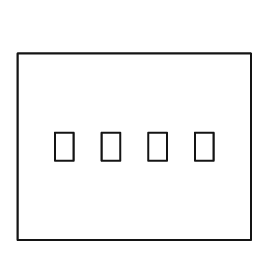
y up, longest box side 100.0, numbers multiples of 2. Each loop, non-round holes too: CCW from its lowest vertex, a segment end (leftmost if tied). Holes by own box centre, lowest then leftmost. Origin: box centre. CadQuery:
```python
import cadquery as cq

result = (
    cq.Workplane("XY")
    .moveTo(-50.0, -40.0)
    .lineTo(50.0, -40.0)
    .lineTo(50.0, 40.0)
    .lineTo(-50.0, 40.0)
    .close()
    .moveTo(-34.0, -6.0)
    .lineTo(-26.0, -6.0)
    .lineTo(-26.0, 6.0)
    .lineTo(-34.0, 6.0)
    .close()
    .moveTo(-14.0, -6.0)
    .lineTo(-6.0, -6.0)
    .lineTo(-6.0, 6.0)
    .lineTo(-14.0, 6.0)
    .close()
    .moveTo(6.0, -6.0)
    .lineTo(14.0, -6.0)
    .lineTo(14.0, 6.0)
    .lineTo(6.0, 6.0)
    .close()
    .moveTo(26.0, -6.0)
    .lineTo(34.0, -6.0)
    .lineTo(34.0, 6.0)
    .lineTo(26.0, 6.0)
    .close()
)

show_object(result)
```